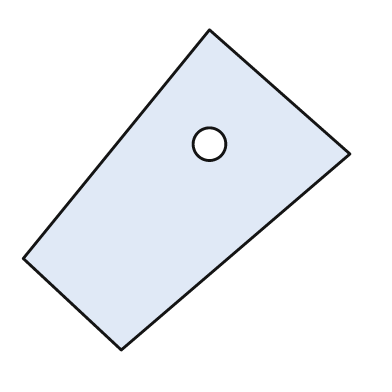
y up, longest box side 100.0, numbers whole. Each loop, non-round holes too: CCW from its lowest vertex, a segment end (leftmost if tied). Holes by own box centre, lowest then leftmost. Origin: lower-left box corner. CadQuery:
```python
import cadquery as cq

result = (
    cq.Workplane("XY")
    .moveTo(30.0, 0.0)
    .lineTo(100.0, 60.0)
    .lineTo(57.0, 98.0)
    .lineTo(0.0, 28.0)
    .close()
    .moveTo(57.0, 63.0)
    .circle(5.0)
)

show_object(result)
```